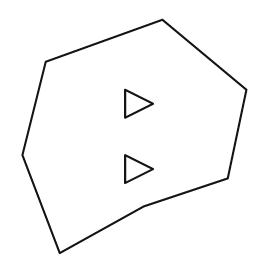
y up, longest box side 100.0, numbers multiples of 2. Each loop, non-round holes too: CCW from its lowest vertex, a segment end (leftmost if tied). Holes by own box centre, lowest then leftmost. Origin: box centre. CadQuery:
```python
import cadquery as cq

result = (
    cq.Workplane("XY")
    .moveTo(-32.0, -50.0)
    .lineTo(4.0, -30.0)
    .lineTo(40.0, -18.0)
    .lineTo(48.0, 20.0)
    .lineTo(12.0, 50.0)
    .lineTo(-38.0, 32.0)
    .lineTo(-48.0, -8.0)
    .close()
    .moveTo(-4.0, -20.0)
    .lineTo(8.0, -14.0)
    .lineTo(-4.0, -8.0)
    .close()
    .moveTo(-4.0, 8.0)
    .lineTo(8.0, 14.0)
    .lineTo(-4.0, 20.0)
    .close()
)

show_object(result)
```